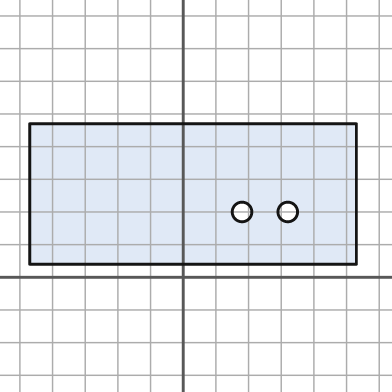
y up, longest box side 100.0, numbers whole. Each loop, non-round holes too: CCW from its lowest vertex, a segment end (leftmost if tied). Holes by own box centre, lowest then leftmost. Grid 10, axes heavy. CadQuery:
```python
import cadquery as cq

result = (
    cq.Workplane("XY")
    .moveTo(-47.0, 4.0)
    .lineTo(53.0, 4.0)
    .lineTo(53.0, 47.0)
    .lineTo(-47.0, 47.0)
    .close()
    .moveTo(18.0, 20.0)
    .circle(3.0)
    .moveTo(32.0, 20.0)
    .circle(3.0)
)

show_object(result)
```